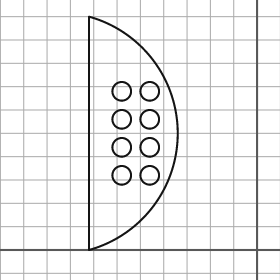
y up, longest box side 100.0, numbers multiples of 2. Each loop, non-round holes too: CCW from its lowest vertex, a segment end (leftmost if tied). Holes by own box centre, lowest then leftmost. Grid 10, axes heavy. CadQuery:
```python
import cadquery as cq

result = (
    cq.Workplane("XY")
    .moveTo(-72.0, 0.0)
    .threePointArc((-34.0, 50.0), (-72.0, 100.0))
    .close()
    .moveTo(-58.0, 32.0)
    .circle(4.0)
    .moveTo(-46.0, 32.0)
    .circle(4.0)
    .moveTo(-58.0, 44.0)
    .circle(4.0)
    .moveTo(-46.0, 44.0)
    .circle(4.0)
    .moveTo(-58.0, 56.0)
    .circle(4.0)
    .moveTo(-46.0, 56.0)
    .circle(4.0)
    .moveTo(-58.0, 68.0)
    .circle(4.0)
    .moveTo(-46.0, 68.0)
    .circle(4.0)
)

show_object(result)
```